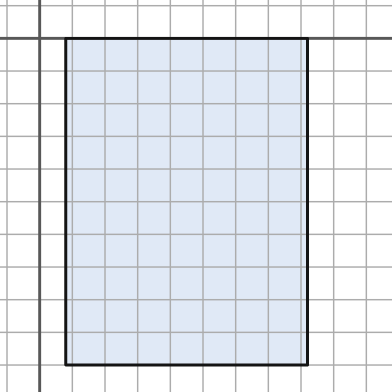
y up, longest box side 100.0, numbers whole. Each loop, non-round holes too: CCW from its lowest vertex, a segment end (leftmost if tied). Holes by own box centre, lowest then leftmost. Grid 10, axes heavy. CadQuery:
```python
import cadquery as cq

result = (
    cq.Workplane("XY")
    .moveTo(8.0, -100.0)
    .lineTo(82.0, -100.0)
    .lineTo(82.0, 0.0)
    .lineTo(8.0, 0.0)
    .close()
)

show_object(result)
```